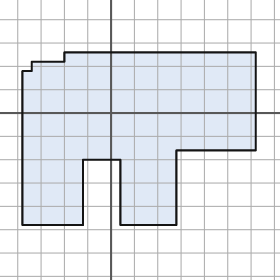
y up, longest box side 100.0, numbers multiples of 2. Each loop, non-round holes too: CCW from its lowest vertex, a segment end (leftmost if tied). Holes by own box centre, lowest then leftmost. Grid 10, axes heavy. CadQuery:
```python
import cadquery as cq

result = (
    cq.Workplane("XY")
    .moveTo(-38.0, -48.0)
    .lineTo(-12.0, -48.0)
    .lineTo(-12.0, -20.0)
    .lineTo(4.0, -20.0)
    .lineTo(4.0, -48.0)
    .lineTo(28.0, -48.0)
    .lineTo(28.0, -16.0)
    .lineTo(62.0, -16.0)
    .lineTo(62.0, 26.0)
    .lineTo(-20.0, 26.0)
    .lineTo(-20.0, 22.0)
    .lineTo(-34.0, 22.0)
    .lineTo(-34.0, 18.0)
    .lineTo(-38.0, 18.0)
    .close()
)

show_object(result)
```